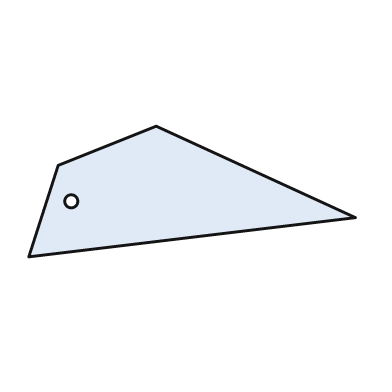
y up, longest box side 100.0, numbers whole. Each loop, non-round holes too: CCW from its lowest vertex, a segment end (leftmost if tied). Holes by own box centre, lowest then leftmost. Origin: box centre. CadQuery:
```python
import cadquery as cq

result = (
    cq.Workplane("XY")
    .moveTo(-50.0, -20.0)
    .lineTo(50.0, -8.0)
    .lineTo(-11.0, 20.0)
    .lineTo(-41.0, 8.0)
    .close()
    .moveTo(-37.0, -3.0)
    .circle(2.0)
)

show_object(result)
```